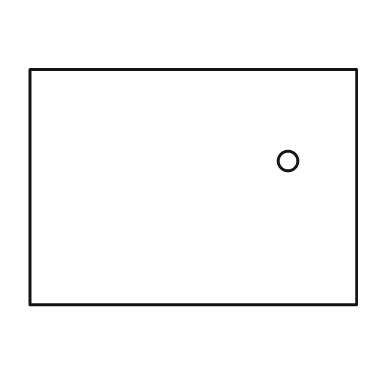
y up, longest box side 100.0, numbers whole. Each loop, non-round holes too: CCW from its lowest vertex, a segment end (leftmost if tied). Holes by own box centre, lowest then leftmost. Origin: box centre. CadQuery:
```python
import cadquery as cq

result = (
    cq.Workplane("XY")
    .moveTo(-50.0, -36.0)
    .lineTo(50.0, -36.0)
    .lineTo(50.0, 36.0)
    .lineTo(-50.0, 36.0)
    .close()
    .moveTo(29.0, 8.0)
    .circle(3.0)
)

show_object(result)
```